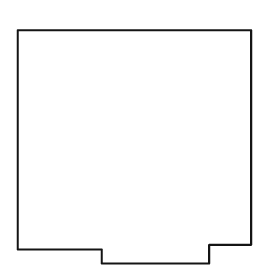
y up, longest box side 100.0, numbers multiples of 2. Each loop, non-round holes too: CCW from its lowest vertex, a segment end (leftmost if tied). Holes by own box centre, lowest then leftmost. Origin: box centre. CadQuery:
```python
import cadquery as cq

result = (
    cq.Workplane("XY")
    .moveTo(-14.0, -50.0)
    .lineTo(32.0, -50.0)
    .lineTo(32.0, -42.0)
    .lineTo(50.0, -42.0)
    .lineTo(50.0, 50.0)
    .lineTo(-50.0, 50.0)
    .lineTo(-50.0, -44.0)
    .lineTo(-14.0, -44.0)
    .close()
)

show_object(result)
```